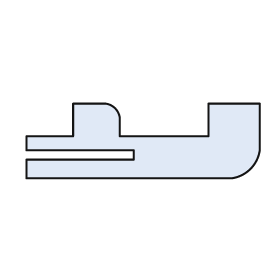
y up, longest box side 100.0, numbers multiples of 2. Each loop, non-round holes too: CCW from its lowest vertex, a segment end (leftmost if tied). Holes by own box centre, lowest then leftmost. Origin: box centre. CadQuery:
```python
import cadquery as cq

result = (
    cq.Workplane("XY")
    .moveTo(-50.0, -16.0)
    .lineTo(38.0, -16.0)
    .threePointArc((46.0, -12.0), (50.0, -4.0))
    .lineTo(50.0, 16.0)
    .lineTo(28.0, 16.0)
    .lineTo(28.0, 2.0)
    .lineTo(-10.0, 2.0)
    .lineTo(-10.0, 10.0)
    .threePointArc((-12.0, 14.0), (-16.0, 16.0))
    .lineTo(-30.0, 16.0)
    .lineTo(-30.0, 2.0)
    .lineTo(-50.0, 2.0)
    .lineTo(-50.0, -4.0)
    .lineTo(-4.0, -4.0)
    .lineTo(-4.0, -8.0)
    .lineTo(-50.0, -8.0)
    .close()
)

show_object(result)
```